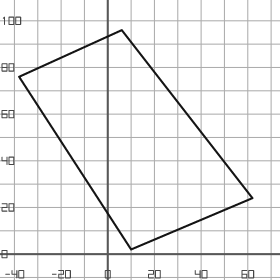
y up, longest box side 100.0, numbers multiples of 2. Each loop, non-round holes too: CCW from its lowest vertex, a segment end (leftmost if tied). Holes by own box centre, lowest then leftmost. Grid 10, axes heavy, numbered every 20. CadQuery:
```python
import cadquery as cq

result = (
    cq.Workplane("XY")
    .moveTo(10.0, 2.0)
    .lineTo(62.0, 24.0)
    .lineTo(6.0, 96.0)
    .lineTo(-38.0, 76.0)
    .close()
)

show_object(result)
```